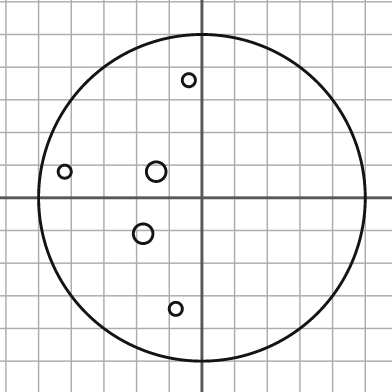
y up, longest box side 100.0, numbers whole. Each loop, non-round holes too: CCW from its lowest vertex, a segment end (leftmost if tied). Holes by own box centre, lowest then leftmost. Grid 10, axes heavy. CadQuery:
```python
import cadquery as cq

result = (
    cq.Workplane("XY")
    .moveTo(0.0, 0.0)
    .circle(50.0)
    .moveTo(-8.0, -34.0)
    .circle(2.0)
    .moveTo(-18.0, -11.0)
    .circle(3.0)
    .moveTo(-42.0, 8.0)
    .circle(2.0)
    .moveTo(-14.0, 8.0)
    .circle(3.0)
    .moveTo(-4.0, 36.0)
    .circle(2.0)
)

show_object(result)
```